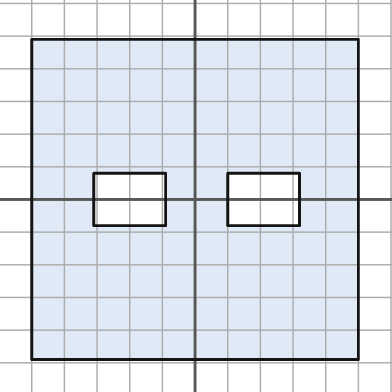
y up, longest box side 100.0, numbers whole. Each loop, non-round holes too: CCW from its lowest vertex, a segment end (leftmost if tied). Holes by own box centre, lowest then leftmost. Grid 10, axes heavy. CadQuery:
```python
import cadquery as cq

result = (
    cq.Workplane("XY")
    .moveTo(-50.0, -49.0)
    .lineTo(50.0, -49.0)
    .lineTo(50.0, 49.0)
    .lineTo(-50.0, 49.0)
    .close()
    .moveTo(-31.0, -8.0)
    .lineTo(-9.0, -8.0)
    .lineTo(-9.0, 8.0)
    .lineTo(-31.0, 8.0)
    .close()
    .moveTo(10.0, -8.0)
    .lineTo(32.0, -8.0)
    .lineTo(32.0, 8.0)
    .lineTo(10.0, 8.0)
    .close()
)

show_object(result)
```